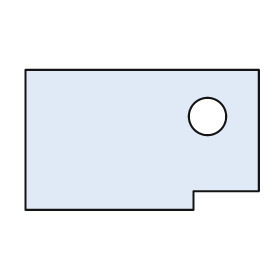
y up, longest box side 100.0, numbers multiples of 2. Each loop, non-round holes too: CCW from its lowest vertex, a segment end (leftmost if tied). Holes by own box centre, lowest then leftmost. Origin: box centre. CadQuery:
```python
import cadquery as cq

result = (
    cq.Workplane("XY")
    .moveTo(-50.0, -30.0)
    .lineTo(22.0, -30.0)
    .lineTo(22.0, -22.0)
    .lineTo(50.0, -22.0)
    .lineTo(50.0, 30.0)
    .lineTo(-50.0, 30.0)
    .close()
    .moveTo(28.0, 10.0)
    .circle(8.0)
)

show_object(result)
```